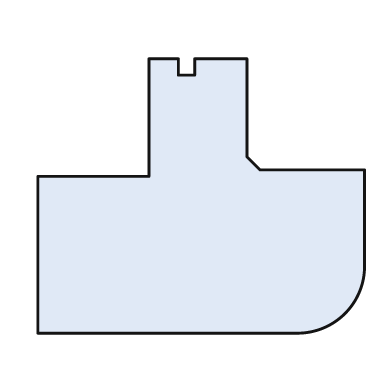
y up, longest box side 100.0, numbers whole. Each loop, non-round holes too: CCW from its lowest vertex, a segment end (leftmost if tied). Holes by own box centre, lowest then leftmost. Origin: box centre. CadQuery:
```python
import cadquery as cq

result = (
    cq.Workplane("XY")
    .moveTo(-50.0, -42.0)
    .lineTo(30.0, -42.0)
    .threePointArc((44.0, -36.0), (50.0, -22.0))
    .lineTo(50.0, 8.0)
    .lineTo(18.0, 8.0)
    .lineTo(14.0, 12.0)
    .lineTo(14.0, 42.0)
    .lineTo(-2.0, 42.0)
    .lineTo(-2.0, 37.0)
    .lineTo(-7.0, 37.0)
    .lineTo(-7.0, 42.0)
    .lineTo(-16.0, 42.0)
    .lineTo(-16.0, 6.0)
    .lineTo(-50.0, 6.0)
    .close()
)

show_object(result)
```